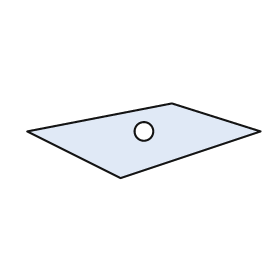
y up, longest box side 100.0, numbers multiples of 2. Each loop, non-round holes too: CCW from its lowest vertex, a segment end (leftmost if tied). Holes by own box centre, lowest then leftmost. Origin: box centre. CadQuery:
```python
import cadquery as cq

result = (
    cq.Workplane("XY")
    .moveTo(-10.0, -16.0)
    .lineTo(50.0, 4.0)
    .lineTo(12.0, 16.0)
    .lineTo(-50.0, 4.0)
    .close()
    .moveTo(0.0, 4.0)
    .circle(4.0)
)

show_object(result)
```